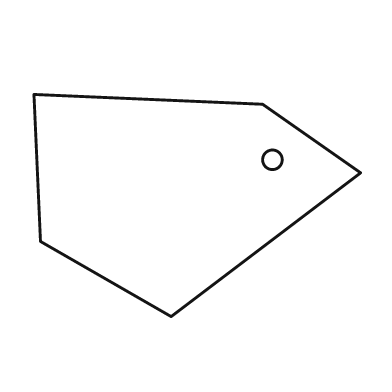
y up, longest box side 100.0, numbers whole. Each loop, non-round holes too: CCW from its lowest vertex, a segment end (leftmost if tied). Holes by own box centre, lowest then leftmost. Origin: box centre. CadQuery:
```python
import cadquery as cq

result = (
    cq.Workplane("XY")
    .moveTo(-8.0, -34.0)
    .lineTo(50.0, 10.0)
    .lineTo(20.0, 31.0)
    .lineTo(-50.0, 34.0)
    .lineTo(-48.0, -11.0)
    .close()
    .moveTo(23.0, 14.0)
    .circle(3.0)
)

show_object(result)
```